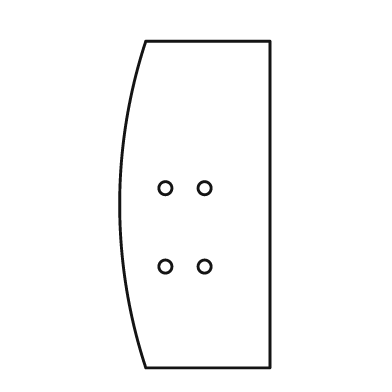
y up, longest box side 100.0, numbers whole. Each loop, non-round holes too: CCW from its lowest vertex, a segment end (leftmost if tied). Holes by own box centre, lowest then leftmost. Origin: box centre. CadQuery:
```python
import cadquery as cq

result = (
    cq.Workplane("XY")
    .moveTo(-15.0, -50.0)
    .lineTo(23.0, -50.0)
    .lineTo(23.0, 50.0)
    .lineTo(-15.0, 50.0)
    .threePointArc((-23.0, 0.0), (-15.0, -50.0))
    .close()
    .moveTo(-9.0, -19.0)
    .circle(2.0)
    .moveTo(3.0, -19.0)
    .circle(2.0)
    .moveTo(-9.0, 5.0)
    .circle(2.0)
    .moveTo(3.0, 5.0)
    .circle(2.0)
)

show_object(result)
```